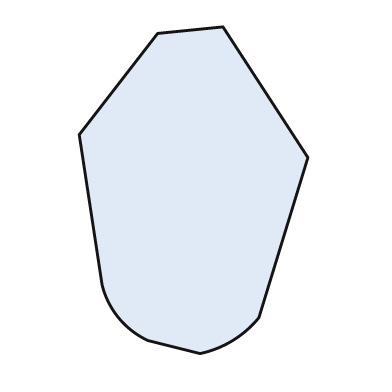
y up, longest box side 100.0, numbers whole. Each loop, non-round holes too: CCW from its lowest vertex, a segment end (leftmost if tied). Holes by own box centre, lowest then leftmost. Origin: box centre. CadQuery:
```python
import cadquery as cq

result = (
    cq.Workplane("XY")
    .moveTo(2.0, -50.0)
    .threePointArc((12.0, -46.0), (20.0, -39.0))
    .lineTo(35.0, 10.0)
    .lineTo(9.0, 50.0)
    .lineTo(-11.0, 48.0)
    .lineTo(-35.0, 17.0)
    .lineTo(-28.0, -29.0)
    .threePointArc((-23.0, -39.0), (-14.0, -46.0))
    .close()
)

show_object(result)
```